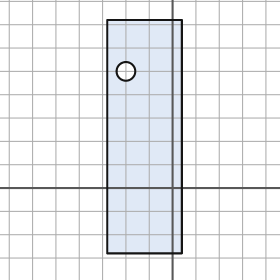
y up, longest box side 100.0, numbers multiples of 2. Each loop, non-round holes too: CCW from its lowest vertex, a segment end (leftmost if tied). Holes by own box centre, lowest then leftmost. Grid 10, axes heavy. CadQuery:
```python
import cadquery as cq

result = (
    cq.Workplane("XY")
    .moveTo(-28.0, -28.0)
    .lineTo(4.0, -28.0)
    .lineTo(4.0, 72.0)
    .lineTo(-28.0, 72.0)
    .close()
    .moveTo(-20.0, 50.0)
    .circle(4.0)
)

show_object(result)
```